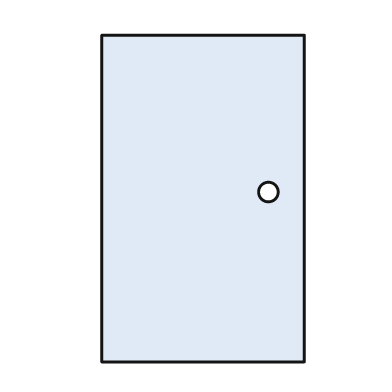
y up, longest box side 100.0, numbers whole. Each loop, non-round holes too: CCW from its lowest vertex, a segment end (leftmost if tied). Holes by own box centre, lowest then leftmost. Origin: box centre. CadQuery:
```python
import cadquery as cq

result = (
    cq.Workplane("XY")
    .moveTo(-31.0, -50.0)
    .lineTo(31.0, -50.0)
    .lineTo(31.0, 50.0)
    .lineTo(-31.0, 50.0)
    .close()
    .moveTo(20.0, 2.0)
    .circle(3.0)
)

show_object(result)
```